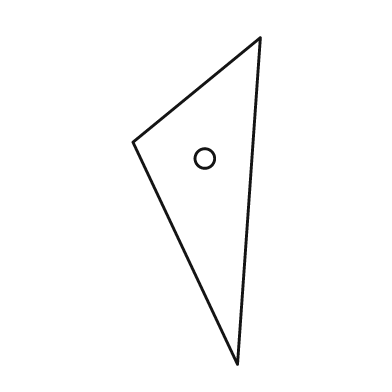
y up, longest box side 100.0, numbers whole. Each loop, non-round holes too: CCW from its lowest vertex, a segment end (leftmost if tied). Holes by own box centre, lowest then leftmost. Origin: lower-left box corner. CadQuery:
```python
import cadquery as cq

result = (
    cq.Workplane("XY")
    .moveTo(32.0, 0.0)
    .lineTo(39.0, 100.0)
    .lineTo(0.0, 68.0)
    .close()
    .moveTo(22.0, 63.0)
    .circle(3.0)
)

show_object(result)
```